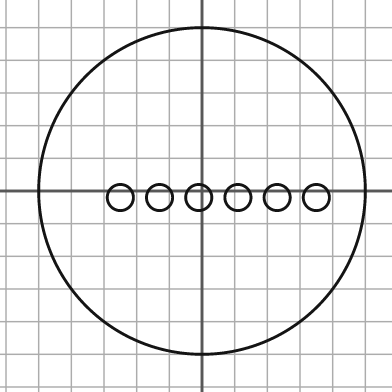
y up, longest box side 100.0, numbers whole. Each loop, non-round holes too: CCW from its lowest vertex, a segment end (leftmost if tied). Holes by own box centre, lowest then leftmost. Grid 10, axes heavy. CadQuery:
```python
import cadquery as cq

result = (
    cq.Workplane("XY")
    .moveTo(0.0, 0.0)
    .circle(50.0)
    .moveTo(-25.0, -2.0)
    .circle(4.0)
    .moveTo(-13.0, -2.0)
    .circle(4.0)
    .moveTo(-1.0, -2.0)
    .circle(4.0)
    .moveTo(11.0, -2.0)
    .circle(4.0)
    .moveTo(23.0, -2.0)
    .circle(4.0)
    .moveTo(35.0, -2.0)
    .circle(4.0)
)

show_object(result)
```